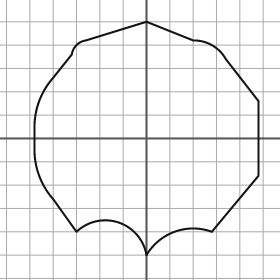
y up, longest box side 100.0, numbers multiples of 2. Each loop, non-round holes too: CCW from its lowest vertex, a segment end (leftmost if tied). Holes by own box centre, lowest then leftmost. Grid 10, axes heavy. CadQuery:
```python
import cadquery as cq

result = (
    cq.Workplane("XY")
    .moveTo(0.0, -50.0)
    .threePointArc((12.0, -40.0), (28.0, -40.0))
    .lineTo(48.0, -16.0)
    .lineTo(48.0, 16.0)
    .lineTo(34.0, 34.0)
    .threePointArc((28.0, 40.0), (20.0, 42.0))
    .lineTo(0.0, 50.0)
    .lineTo(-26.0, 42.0)
    .threePointArc((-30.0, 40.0), (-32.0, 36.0))
    .lineTo(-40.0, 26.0)
    .threePointArc((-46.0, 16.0), (-48.0, 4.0))
    .lineTo(-48.0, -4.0)
    .threePointArc((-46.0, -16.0), (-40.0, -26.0))
    .lineTo(-30.0, -40.0)
    .threePointArc((-12.0, -36.0), (0.0, -50.0))
    .close()
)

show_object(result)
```